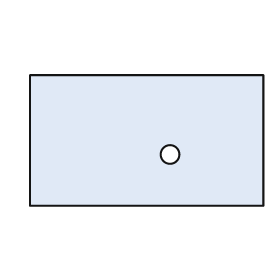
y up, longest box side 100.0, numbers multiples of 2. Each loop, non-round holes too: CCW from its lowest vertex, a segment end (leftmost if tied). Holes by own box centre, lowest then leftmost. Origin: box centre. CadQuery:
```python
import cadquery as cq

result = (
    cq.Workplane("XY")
    .moveTo(-50.0, -28.0)
    .lineTo(50.0, -28.0)
    .lineTo(50.0, 28.0)
    .lineTo(-50.0, 28.0)
    .close()
    .moveTo(10.0, -6.0)
    .circle(4.0)
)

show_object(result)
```